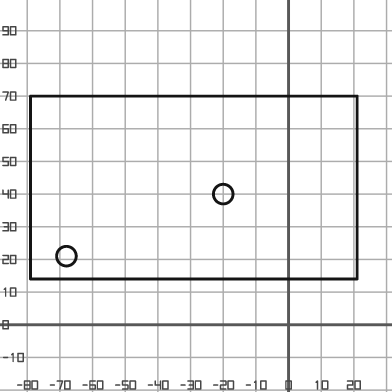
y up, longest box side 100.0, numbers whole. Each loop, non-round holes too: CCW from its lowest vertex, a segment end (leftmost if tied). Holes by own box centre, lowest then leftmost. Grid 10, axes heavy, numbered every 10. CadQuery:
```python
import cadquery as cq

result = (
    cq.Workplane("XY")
    .moveTo(-79.0, 14.0)
    .lineTo(21.0, 14.0)
    .lineTo(21.0, 70.0)
    .lineTo(-79.0, 70.0)
    .close()
    .moveTo(-68.0, 21.0)
    .circle(3.0)
    .moveTo(-20.0, 40.0)
    .circle(3.0)
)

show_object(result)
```